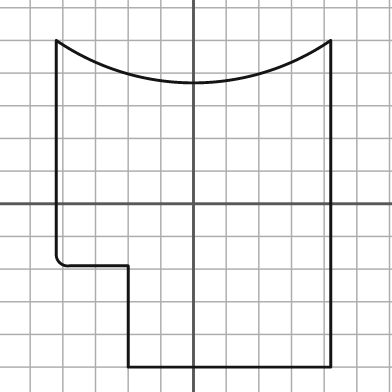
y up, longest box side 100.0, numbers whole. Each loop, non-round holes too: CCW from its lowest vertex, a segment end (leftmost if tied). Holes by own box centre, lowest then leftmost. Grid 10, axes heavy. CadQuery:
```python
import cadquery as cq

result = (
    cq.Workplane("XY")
    .moveTo(-20.0, -50.0)
    .lineTo(42.0, -50.0)
    .lineTo(42.0, 50.0)
    .threePointArc((0.0, 37.0), (-42.0, 50.0))
    .lineTo(-42.0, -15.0)
    .threePointArc((-41.0, -18.0), (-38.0, -19.0))
    .lineTo(-20.0, -19.0)
    .close()
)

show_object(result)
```